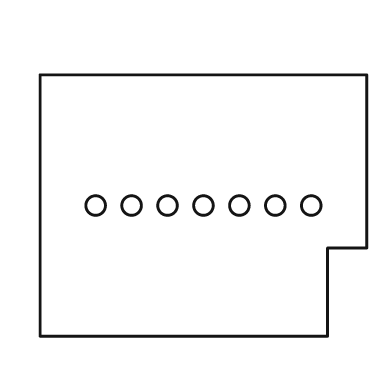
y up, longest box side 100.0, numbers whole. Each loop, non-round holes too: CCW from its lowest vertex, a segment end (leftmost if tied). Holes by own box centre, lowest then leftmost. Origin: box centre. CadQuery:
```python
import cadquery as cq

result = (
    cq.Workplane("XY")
    .moveTo(-50.0, -40.0)
    .lineTo(38.0, -40.0)
    .lineTo(38.0, -13.0)
    .lineTo(50.0, -13.0)
    .lineTo(50.0, 40.0)
    .lineTo(-50.0, 40.0)
    .close()
    .moveTo(-33.0, 0.0)
    .circle(3.0)
    .moveTo(-22.0, 0.0)
    .circle(3.0)
    .moveTo(-11.0, 0.0)
    .circle(3.0)
    .moveTo(0.0, 0.0)
    .circle(3.0)
    .moveTo(11.0, 0.0)
    .circle(3.0)
    .moveTo(22.0, 0.0)
    .circle(3.0)
    .moveTo(33.0, 0.0)
    .circle(3.0)
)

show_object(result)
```